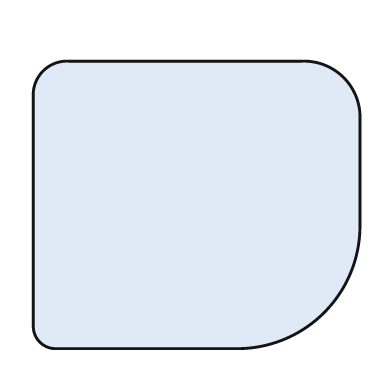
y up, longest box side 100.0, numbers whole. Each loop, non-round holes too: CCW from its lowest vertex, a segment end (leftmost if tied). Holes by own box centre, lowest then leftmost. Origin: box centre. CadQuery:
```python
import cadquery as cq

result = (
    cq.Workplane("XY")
    .moveTo(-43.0, -44.0)
    .lineTo(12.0, -44.0)
    .threePointArc((39.0, -33.0), (50.0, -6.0))
    .lineTo(50.0, 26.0)
    .threePointArc((45.0, 39.0), (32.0, 44.0))
    .lineTo(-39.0, 44.0)
    .threePointArc((-47.0, 41.0), (-50.0, 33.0))
    .lineTo(-50.0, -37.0)
    .threePointArc((-48.0, -42.0), (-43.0, -44.0))
    .close()
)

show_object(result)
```